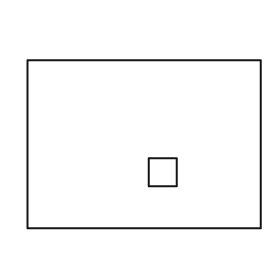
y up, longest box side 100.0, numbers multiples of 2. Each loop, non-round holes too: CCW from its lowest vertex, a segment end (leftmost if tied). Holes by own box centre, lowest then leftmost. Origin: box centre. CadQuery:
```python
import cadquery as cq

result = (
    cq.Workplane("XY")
    .moveTo(-50.0, -36.0)
    .lineTo(50.0, -36.0)
    .lineTo(50.0, 36.0)
    .lineTo(-50.0, 36.0)
    .close()
    .moveTo(2.0, -18.0)
    .lineTo(14.0, -18.0)
    .lineTo(14.0, -6.0)
    .lineTo(2.0, -6.0)
    .close()
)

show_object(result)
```